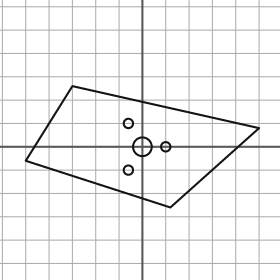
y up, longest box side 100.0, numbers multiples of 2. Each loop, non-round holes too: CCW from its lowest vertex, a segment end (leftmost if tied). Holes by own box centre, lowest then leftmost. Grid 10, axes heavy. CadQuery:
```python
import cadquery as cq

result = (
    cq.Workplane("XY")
    .moveTo(12.0, -26.0)
    .lineTo(50.0, 8.0)
    .lineTo(-30.0, 26.0)
    .lineTo(-50.0, -6.0)
    .close()
    .moveTo(-6.0, -10.0)
    .circle(2.0)
    .moveTo(0.0, 0.0)
    .circle(4.0)
    .moveTo(10.0, 0.0)
    .circle(2.0)
    .moveTo(-6.0, 10.0)
    .circle(2.0)
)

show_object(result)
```